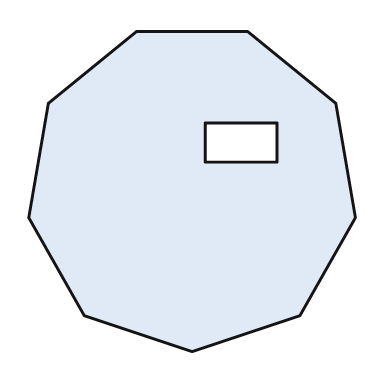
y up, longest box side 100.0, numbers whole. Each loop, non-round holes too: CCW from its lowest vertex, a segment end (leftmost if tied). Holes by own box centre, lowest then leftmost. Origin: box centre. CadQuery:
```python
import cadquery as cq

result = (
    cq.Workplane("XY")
    .moveTo(0.0, -49.0)
    .lineTo(33.0, -38.0)
    .lineTo(50.0, -8.0)
    .lineTo(44.0, 27.0)
    .lineTo(17.0, 49.0)
    .lineTo(-17.0, 49.0)
    .lineTo(-44.0, 27.0)
    .lineTo(-50.0, -8.0)
    .lineTo(-33.0, -38.0)
    .close()
    .moveTo(4.0, 9.0)
    .lineTo(26.0, 9.0)
    .lineTo(26.0, 21.0)
    .lineTo(4.0, 21.0)
    .close()
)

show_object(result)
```